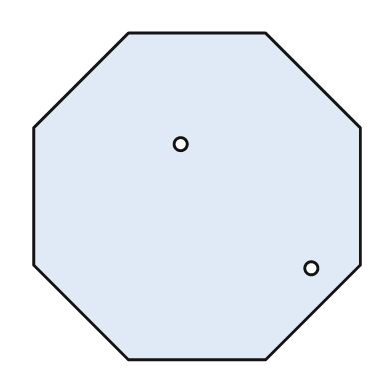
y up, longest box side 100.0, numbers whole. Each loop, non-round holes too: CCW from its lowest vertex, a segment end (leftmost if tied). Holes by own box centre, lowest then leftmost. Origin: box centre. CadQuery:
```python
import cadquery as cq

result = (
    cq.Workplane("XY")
    .moveTo(-21.0, -50.0)
    .lineTo(21.0, -50.0)
    .lineTo(50.0, -21.0)
    .lineTo(50.0, 21.0)
    .lineTo(21.0, 50.0)
    .lineTo(-21.0, 50.0)
    .lineTo(-50.0, 21.0)
    .lineTo(-50.0, -21.0)
    .close()
    .moveTo(35.0, -22.0)
    .circle(2.0)
    .moveTo(-5.0, 16.0)
    .circle(2.0)
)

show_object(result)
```